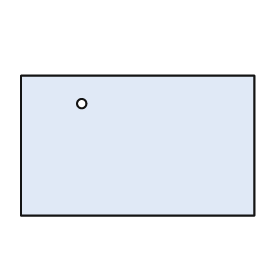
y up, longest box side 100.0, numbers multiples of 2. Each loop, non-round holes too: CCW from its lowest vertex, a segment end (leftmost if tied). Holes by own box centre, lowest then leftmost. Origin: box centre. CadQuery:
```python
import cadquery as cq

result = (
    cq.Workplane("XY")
    .moveTo(-50.0, -30.0)
    .lineTo(50.0, -30.0)
    .lineTo(50.0, 30.0)
    .lineTo(-50.0, 30.0)
    .close()
    .moveTo(-24.0, 18.0)
    .circle(2.0)
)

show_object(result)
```